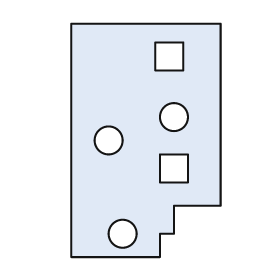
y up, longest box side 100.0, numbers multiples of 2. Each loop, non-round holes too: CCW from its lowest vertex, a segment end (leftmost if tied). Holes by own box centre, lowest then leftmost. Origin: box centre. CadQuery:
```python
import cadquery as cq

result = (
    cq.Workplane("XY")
    .moveTo(-32.0, -50.0)
    .lineTo(6.0, -50.0)
    .lineTo(6.0, -40.0)
    .lineTo(12.0, -40.0)
    .lineTo(12.0, -28.0)
    .lineTo(32.0, -28.0)
    .lineTo(32.0, 50.0)
    .lineTo(-32.0, 50.0)
    .close()
    .moveTo(-10.0, -40.0)
    .circle(6.0)
    .moveTo(6.0, -18.0)
    .lineTo(18.0, -18.0)
    .lineTo(18.0, -6.0)
    .lineTo(6.0, -6.0)
    .close()
    .moveTo(-16.0, 0.0)
    .circle(6.0)
    .moveTo(12.0, 10.0)
    .circle(6.0)
    .moveTo(4.0, 30.0)
    .lineTo(16.0, 30.0)
    .lineTo(16.0, 42.0)
    .lineTo(4.0, 42.0)
    .close()
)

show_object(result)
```